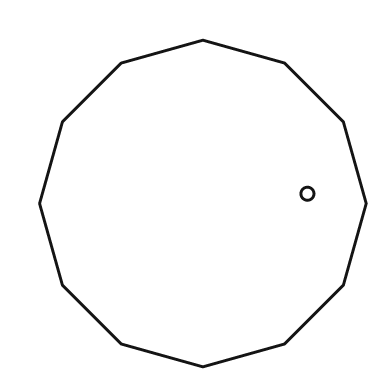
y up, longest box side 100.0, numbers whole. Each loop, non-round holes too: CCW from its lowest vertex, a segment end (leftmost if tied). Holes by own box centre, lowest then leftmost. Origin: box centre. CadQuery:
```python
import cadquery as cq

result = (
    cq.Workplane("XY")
    .moveTo(0.0, -50.0)
    .lineTo(25.0, -43.0)
    .lineTo(43.0, -25.0)
    .lineTo(50.0, 0.0)
    .lineTo(43.0, 25.0)
    .lineTo(25.0, 43.0)
    .lineTo(0.0, 50.0)
    .lineTo(-25.0, 43.0)
    .lineTo(-43.0, 25.0)
    .lineTo(-50.0, 0.0)
    .lineTo(-43.0, -25.0)
    .lineTo(-25.0, -43.0)
    .close()
    .moveTo(32.0, 3.0)
    .circle(2.0)
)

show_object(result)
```